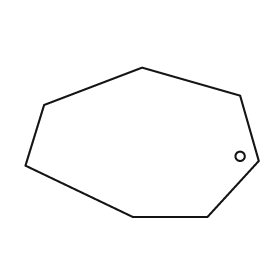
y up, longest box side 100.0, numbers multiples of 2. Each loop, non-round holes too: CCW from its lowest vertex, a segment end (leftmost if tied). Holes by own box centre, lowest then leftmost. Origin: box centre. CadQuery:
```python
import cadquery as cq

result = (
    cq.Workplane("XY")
    .moveTo(-4.0, -32.0)
    .lineTo(28.0, -32.0)
    .lineTo(50.0, -8.0)
    .lineTo(42.0, 20.0)
    .lineTo(0.0, 32.0)
    .lineTo(-42.0, 16.0)
    .lineTo(-50.0, -10.0)
    .close()
    .moveTo(42.0, -6.0)
    .circle(2.0)
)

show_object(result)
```